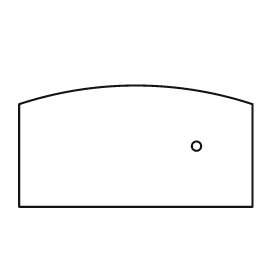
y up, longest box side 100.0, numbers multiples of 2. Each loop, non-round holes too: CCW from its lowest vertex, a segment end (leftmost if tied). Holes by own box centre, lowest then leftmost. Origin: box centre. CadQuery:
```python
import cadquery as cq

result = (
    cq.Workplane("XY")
    .moveTo(-50.0, -26.0)
    .lineTo(50.0, -26.0)
    .lineTo(50.0, 18.0)
    .threePointArc((0.0, 26.0), (-50.0, 18.0))
    .close()
    .moveTo(26.0, 0.0)
    .circle(2.0)
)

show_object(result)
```